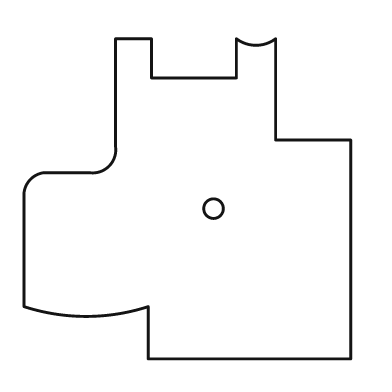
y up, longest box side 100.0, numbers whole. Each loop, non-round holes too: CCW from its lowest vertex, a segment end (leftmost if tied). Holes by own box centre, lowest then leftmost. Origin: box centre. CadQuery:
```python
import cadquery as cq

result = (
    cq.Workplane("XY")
    .moveTo(-12.0, -49.0)
    .lineTo(50.0, -49.0)
    .lineTo(50.0, 18.0)
    .lineTo(27.0, 18.0)
    .lineTo(27.0, 49.0)
    .threePointArc((21.0, 47.0), (15.0, 49.0))
    .lineTo(15.0, 37.0)
    .lineTo(-11.0, 37.0)
    .lineTo(-11.0, 49.0)
    .lineTo(-22.0, 49.0)
    .lineTo(-22.0, 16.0)
    .threePointArc((-24.0, 10.0), (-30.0, 8.0))
    .lineTo(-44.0, 8.0)
    .threePointArc((-48.0, 6.0), (-50.0, 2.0))
    .lineTo(-50.0, -33.0)
    .threePointArc((-31.0, -36.0), (-12.0, -33.0))
    .close()
    .moveTo(8.0, -3.0)
    .circle(3.0)
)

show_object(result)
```